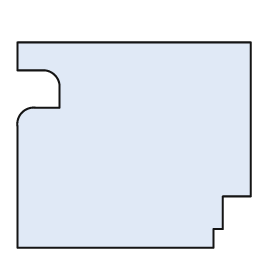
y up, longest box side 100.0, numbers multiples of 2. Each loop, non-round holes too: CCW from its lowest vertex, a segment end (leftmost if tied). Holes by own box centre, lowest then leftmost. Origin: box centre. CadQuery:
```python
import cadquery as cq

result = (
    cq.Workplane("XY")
    .moveTo(-50.0, -44.0)
    .lineTo(34.0, -44.0)
    .lineTo(34.0, -36.0)
    .lineTo(38.0, -36.0)
    .lineTo(38.0, -22.0)
    .lineTo(50.0, -22.0)
    .lineTo(50.0, 44.0)
    .lineTo(-50.0, 44.0)
    .lineTo(-50.0, 32.0)
    .lineTo(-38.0, 32.0)
    .threePointArc((-34.0, 30.0), (-32.0, 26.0))
    .lineTo(-32.0, 16.0)
    .lineTo(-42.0, 16.0)
    .threePointArc((-48.0, 14.0), (-50.0, 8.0))
    .close()
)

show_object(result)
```